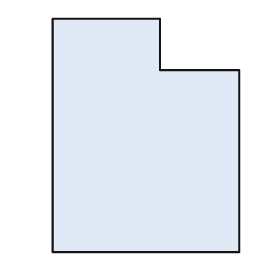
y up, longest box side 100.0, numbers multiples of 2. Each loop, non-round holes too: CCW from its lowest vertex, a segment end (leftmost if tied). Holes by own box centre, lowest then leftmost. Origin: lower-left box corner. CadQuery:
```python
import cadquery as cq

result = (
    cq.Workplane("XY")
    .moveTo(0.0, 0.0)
    .lineTo(80.0, 0.0)
    .lineTo(80.0, 78.0)
    .lineTo(46.0, 78.0)
    .lineTo(46.0, 100.0)
    .lineTo(0.0, 100.0)
    .close()
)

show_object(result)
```